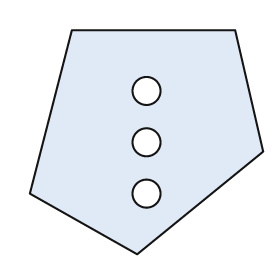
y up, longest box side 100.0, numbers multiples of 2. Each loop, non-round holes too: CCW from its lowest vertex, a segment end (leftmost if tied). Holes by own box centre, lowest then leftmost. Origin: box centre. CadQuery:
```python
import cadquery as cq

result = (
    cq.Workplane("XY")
    .moveTo(-4.0, -48.0)
    .lineTo(50.0, -4.0)
    .lineTo(38.0, 48.0)
    .lineTo(-32.0, 48.0)
    .lineTo(-50.0, -22.0)
    .close()
    .moveTo(0.0, -22.0)
    .circle(6.0)
    .moveTo(0.0, 0.0)
    .circle(6.0)
    .moveTo(0.0, 22.0)
    .circle(6.0)
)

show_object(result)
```